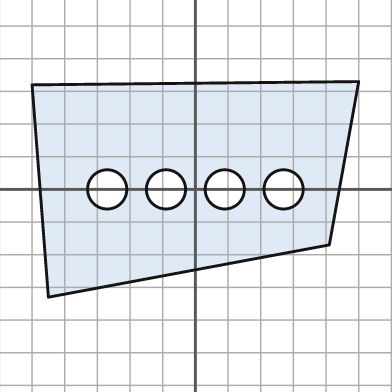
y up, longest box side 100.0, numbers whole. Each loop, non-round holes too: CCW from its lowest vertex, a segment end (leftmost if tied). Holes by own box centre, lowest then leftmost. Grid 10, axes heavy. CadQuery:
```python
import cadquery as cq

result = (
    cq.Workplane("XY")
    .moveTo(-45.0, -33.0)
    .lineTo(41.0, -17.0)
    .lineTo(50.0, 33.0)
    .lineTo(-50.0, 32.0)
    .close()
    .moveTo(-27.0, 0.0)
    .circle(6.0)
    .moveTo(-9.0, 0.0)
    .circle(6.0)
    .moveTo(9.0, 0.0)
    .circle(6.0)
    .moveTo(27.0, 0.0)
    .circle(6.0)
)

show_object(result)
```